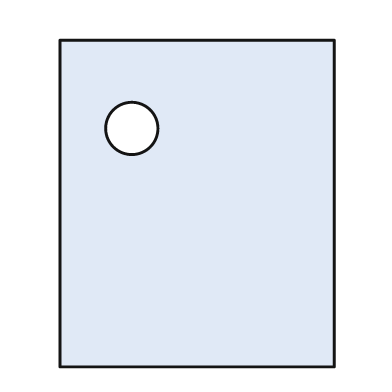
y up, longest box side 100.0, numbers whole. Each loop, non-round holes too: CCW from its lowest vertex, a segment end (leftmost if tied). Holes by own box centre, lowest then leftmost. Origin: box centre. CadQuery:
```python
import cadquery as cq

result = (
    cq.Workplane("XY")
    .moveTo(-42.0, -50.0)
    .lineTo(42.0, -50.0)
    .lineTo(42.0, 50.0)
    .lineTo(-42.0, 50.0)
    .close()
    .moveTo(-20.0, 23.0)
    .circle(8.0)
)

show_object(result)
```